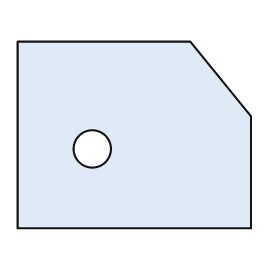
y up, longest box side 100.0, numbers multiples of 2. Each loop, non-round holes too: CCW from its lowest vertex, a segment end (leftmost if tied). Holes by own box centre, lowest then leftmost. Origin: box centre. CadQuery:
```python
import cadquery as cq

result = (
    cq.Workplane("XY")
    .moveTo(-50.0, -40.0)
    .lineTo(50.0, -40.0)
    .lineTo(50.0, 8.0)
    .lineTo(24.0, 40.0)
    .lineTo(-50.0, 40.0)
    .close()
    .moveTo(-18.0, -6.0)
    .circle(8.0)
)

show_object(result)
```